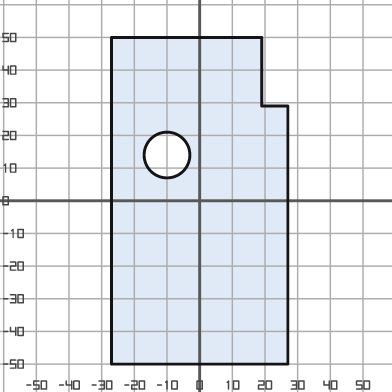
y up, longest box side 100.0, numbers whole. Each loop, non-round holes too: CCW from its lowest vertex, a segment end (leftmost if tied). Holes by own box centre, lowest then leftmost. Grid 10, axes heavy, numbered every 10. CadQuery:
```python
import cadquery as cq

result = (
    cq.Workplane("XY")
    .moveTo(-27.0, -50.0)
    .lineTo(27.0, -50.0)
    .lineTo(27.0, 29.0)
    .lineTo(19.0, 29.0)
    .lineTo(19.0, 50.0)
    .lineTo(-27.0, 50.0)
    .close()
    .moveTo(-10.0, 14.0)
    .circle(7.0)
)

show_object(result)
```